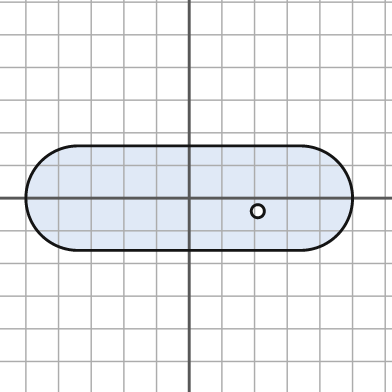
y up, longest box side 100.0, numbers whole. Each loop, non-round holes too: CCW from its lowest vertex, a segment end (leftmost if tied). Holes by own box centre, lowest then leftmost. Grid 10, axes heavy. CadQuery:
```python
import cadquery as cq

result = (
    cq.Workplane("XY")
    .moveTo(-34.0, -16.0)
    .lineTo(34.0, -16.0)
    .threePointArc((50.0, 0.0), (34.0, 16.0))
    .lineTo(-34.0, 16.0)
    .threePointArc((-50.0, 0.0), (-34.0, -16.0))
    .close()
    .moveTo(21.0, -4.0)
    .circle(2.0)
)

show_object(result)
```